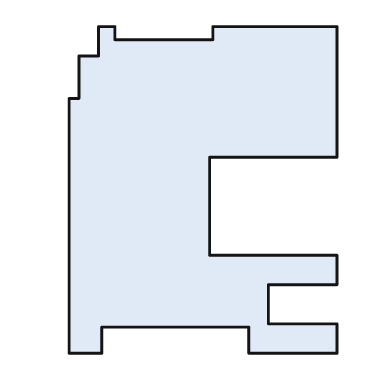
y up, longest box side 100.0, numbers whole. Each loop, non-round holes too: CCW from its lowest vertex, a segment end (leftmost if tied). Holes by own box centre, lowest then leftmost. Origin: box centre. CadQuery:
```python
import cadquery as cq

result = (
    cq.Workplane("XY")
    .moveTo(-41.0, -50.0)
    .lineTo(-31.0, -50.0)
    .lineTo(-31.0, -42.0)
    .lineTo(14.0, -42.0)
    .lineTo(14.0, -50.0)
    .lineTo(41.0, -50.0)
    .lineTo(41.0, -41.0)
    .lineTo(20.0, -41.0)
    .lineTo(20.0, -29.0)
    .lineTo(41.0, -29.0)
    .lineTo(41.0, -20.0)
    .lineTo(2.0, -20.0)
    .lineTo(2.0, 10.0)
    .lineTo(41.0, 10.0)
    .lineTo(41.0, 50.0)
    .lineTo(3.0, 50.0)
    .lineTo(3.0, 46.0)
    .lineTo(-27.0, 46.0)
    .lineTo(-27.0, 50.0)
    .lineTo(-32.0, 50.0)
    .lineTo(-32.0, 41.0)
    .lineTo(-38.0, 41.0)
    .lineTo(-38.0, 28.0)
    .lineTo(-41.0, 28.0)
    .close()
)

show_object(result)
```